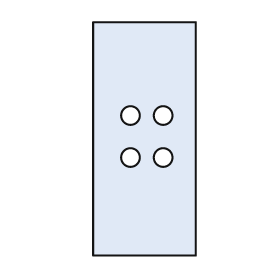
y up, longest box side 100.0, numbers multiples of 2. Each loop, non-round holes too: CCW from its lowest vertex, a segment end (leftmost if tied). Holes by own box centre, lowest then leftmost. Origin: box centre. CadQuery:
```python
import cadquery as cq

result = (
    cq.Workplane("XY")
    .moveTo(-22.0, -50.0)
    .lineTo(22.0, -50.0)
    .lineTo(22.0, 50.0)
    .lineTo(-22.0, 50.0)
    .close()
    .moveTo(-6.0, -8.0)
    .circle(4.0)
    .moveTo(8.0, -8.0)
    .circle(4.0)
    .moveTo(-6.0, 10.0)
    .circle(4.0)
    .moveTo(8.0, 10.0)
    .circle(4.0)
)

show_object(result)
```